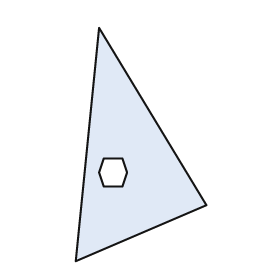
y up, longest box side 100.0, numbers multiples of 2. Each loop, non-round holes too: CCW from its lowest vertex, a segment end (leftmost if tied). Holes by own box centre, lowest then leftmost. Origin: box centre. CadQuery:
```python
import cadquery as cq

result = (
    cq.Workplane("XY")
    .moveTo(-28.0, -50.0)
    .lineTo(28.0, -26.0)
    .lineTo(-18.0, 50.0)
    .close()
    .moveTo(-16.0, -18.0)
    .lineTo(-8.0, -18.0)
    .lineTo(-6.0, -12.0)
    .lineTo(-8.0, -6.0)
    .lineTo(-16.0, -6.0)
    .lineTo(-18.0, -12.0)
    .close()
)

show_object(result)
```